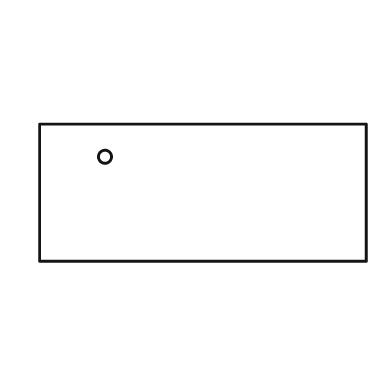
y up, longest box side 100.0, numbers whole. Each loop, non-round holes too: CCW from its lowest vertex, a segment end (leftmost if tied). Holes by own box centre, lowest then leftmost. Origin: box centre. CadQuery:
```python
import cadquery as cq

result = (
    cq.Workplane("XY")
    .moveTo(-50.0, -21.0)
    .lineTo(50.0, -21.0)
    .lineTo(50.0, 21.0)
    .lineTo(-50.0, 21.0)
    .close()
    .moveTo(-30.0, 11.0)
    .circle(2.0)
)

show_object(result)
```